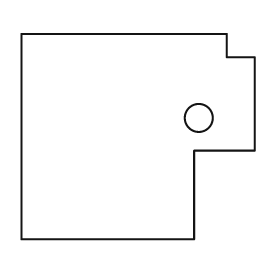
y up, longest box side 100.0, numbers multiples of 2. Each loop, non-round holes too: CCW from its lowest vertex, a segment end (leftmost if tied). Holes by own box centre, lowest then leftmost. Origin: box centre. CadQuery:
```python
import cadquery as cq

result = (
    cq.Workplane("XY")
    .moveTo(-50.0, -44.0)
    .lineTo(24.0, -44.0)
    .lineTo(24.0, -6.0)
    .lineTo(50.0, -6.0)
    .lineTo(50.0, 34.0)
    .lineTo(38.0, 34.0)
    .lineTo(38.0, 44.0)
    .lineTo(-50.0, 44.0)
    .close()
    .moveTo(26.0, 8.0)
    .circle(6.0)
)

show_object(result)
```